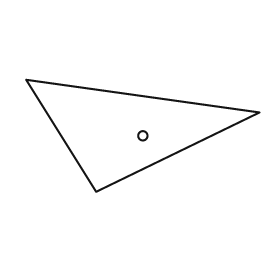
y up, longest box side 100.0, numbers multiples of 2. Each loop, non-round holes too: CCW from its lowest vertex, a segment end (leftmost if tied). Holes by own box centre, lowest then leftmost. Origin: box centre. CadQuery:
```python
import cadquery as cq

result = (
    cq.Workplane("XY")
    .moveTo(-20.0, -24.0)
    .lineTo(50.0, 10.0)
    .lineTo(-50.0, 24.0)
    .close()
    .moveTo(0.0, 0.0)
    .circle(2.0)
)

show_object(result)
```